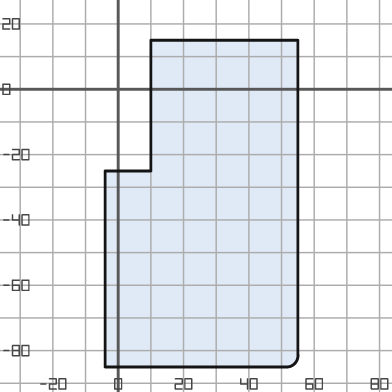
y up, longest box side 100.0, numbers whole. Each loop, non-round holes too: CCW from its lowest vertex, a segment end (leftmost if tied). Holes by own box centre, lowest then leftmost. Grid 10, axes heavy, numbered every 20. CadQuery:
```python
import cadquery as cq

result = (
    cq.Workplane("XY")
    .moveTo(-4.0, -85.0)
    .lineTo(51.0, -85.0)
    .threePointArc((54.0, -84.0), (55.0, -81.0))
    .lineTo(55.0, 15.0)
    .lineTo(10.0, 15.0)
    .lineTo(10.0, -25.0)
    .lineTo(-4.0, -25.0)
    .close()
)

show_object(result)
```